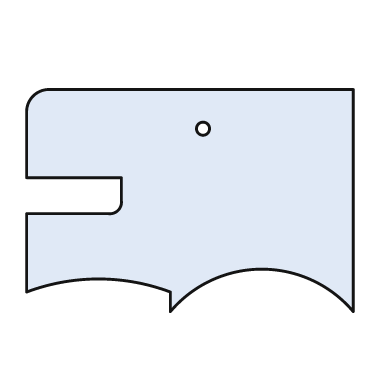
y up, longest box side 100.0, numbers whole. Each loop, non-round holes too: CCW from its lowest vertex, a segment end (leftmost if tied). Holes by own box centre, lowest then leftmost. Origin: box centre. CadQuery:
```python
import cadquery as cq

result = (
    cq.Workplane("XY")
    .moveTo(-6.0, -34.0)
    .threePointArc((22.0, -21.0), (50.0, -34.0))
    .lineTo(50.0, 34.0)
    .lineTo(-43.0, 34.0)
    .threePointArc((-48.0, 32.0), (-50.0, 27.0))
    .lineTo(-50.0, 7.0)
    .lineTo(-21.0, 7.0)
    .lineTo(-21.0, 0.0)
    .threePointArc((-22.0, -3.0), (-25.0, -4.0))
    .lineTo(-50.0, -4.0)
    .lineTo(-50.0, -28.0)
    .threePointArc((-28.0, -24.0), (-6.0, -28.0))
    .close()
    .moveTo(4.0, 22.0)
    .circle(2.0)
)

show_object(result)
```